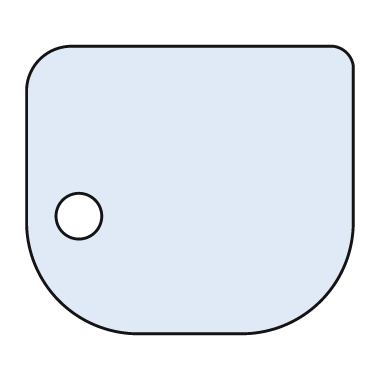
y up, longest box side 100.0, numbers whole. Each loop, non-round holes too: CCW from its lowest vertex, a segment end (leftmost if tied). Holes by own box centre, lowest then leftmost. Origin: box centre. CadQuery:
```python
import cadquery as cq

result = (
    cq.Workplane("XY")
    .moveTo(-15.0, -44.0)
    .lineTo(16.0, -44.0)
    .threePointArc((40.0, -34.0), (50.0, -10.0))
    .lineTo(50.0, 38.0)
    .threePointArc((48.0, 42.0), (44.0, 44.0))
    .lineTo(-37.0, 44.0)
    .threePointArc((-46.0, 40.0), (-50.0, 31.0))
    .lineTo(-50.0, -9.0)
    .threePointArc((-40.0, -34.0), (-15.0, -44.0))
    .close()
    .moveTo(-34.0, -8.0)
    .circle(7.0)
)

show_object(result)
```